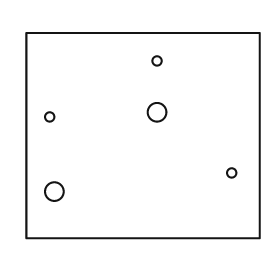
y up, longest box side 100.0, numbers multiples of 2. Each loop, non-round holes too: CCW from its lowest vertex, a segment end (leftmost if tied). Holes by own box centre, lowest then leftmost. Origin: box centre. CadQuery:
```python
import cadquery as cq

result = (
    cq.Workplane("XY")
    .moveTo(-50.0, -44.0)
    .lineTo(50.0, -44.0)
    .lineTo(50.0, 44.0)
    .lineTo(-50.0, 44.0)
    .close()
    .moveTo(-38.0, -24.0)
    .circle(4.0)
    .moveTo(38.0, -16.0)
    .circle(2.0)
    .moveTo(-40.0, 8.0)
    .circle(2.0)
    .moveTo(6.0, 10.0)
    .circle(4.0)
    .moveTo(6.0, 32.0)
    .circle(2.0)
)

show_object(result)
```